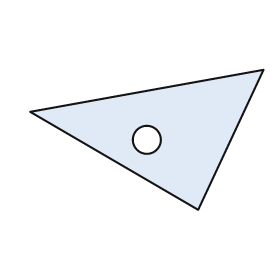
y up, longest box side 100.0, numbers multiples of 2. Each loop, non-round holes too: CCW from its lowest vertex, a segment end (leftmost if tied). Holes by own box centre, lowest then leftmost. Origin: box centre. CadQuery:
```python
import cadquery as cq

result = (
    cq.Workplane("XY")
    .moveTo(22.0, -30.0)
    .lineTo(50.0, 30.0)
    .lineTo(-50.0, 12.0)
    .close()
    .moveTo(0.0, 0.0)
    .circle(6.0)
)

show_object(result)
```